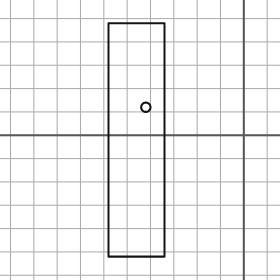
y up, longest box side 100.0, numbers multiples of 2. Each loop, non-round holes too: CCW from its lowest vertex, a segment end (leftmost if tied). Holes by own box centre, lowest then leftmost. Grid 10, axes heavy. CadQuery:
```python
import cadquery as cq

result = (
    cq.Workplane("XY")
    .moveTo(-58.0, -52.0)
    .lineTo(-34.0, -52.0)
    .lineTo(-34.0, 48.0)
    .lineTo(-58.0, 48.0)
    .close()
    .moveTo(-42.0, 12.0)
    .circle(2.0)
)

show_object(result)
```